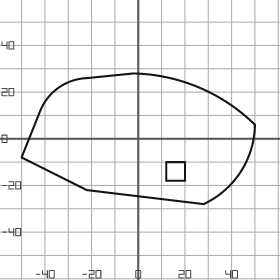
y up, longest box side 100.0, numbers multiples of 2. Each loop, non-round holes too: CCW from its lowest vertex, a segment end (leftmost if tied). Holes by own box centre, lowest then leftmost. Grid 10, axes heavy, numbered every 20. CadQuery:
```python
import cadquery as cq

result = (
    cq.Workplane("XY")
    .moveTo(28.0, -28.0)
    .threePointArc((44.0, -14.0), (50.0, 6.0))
    .threePointArc((26.0, 22.0), (-2.0, 28.0))
    .lineTo(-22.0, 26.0)
    .threePointArc((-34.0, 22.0), (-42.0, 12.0))
    .lineTo(-50.0, -8.0)
    .lineTo(-22.0, -22.0)
    .close()
    .moveTo(12.0, -18.0)
    .lineTo(20.0, -18.0)
    .lineTo(20.0, -10.0)
    .lineTo(12.0, -10.0)
    .close()
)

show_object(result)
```